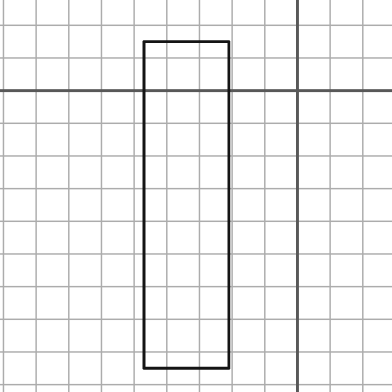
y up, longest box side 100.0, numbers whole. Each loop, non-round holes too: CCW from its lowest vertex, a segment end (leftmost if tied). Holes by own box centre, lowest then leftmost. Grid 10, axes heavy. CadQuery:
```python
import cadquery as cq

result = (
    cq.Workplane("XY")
    .moveTo(-47.0, -85.0)
    .lineTo(-21.0, -85.0)
    .lineTo(-21.0, 15.0)
    .lineTo(-47.0, 15.0)
    .close()
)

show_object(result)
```